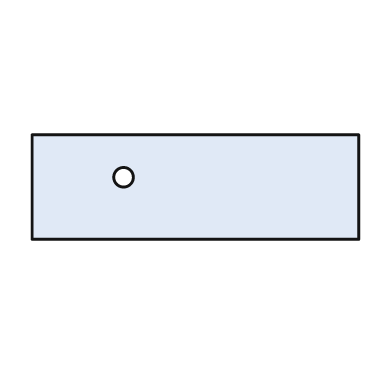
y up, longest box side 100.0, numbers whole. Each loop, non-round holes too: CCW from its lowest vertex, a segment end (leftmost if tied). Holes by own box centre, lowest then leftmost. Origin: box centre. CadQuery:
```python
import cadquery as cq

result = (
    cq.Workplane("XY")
    .moveTo(-50.0, -16.0)
    .lineTo(50.0, -16.0)
    .lineTo(50.0, 16.0)
    .lineTo(-50.0, 16.0)
    .close()
    .moveTo(-22.0, 3.0)
    .circle(3.0)
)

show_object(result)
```